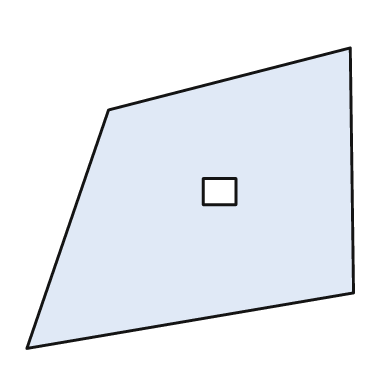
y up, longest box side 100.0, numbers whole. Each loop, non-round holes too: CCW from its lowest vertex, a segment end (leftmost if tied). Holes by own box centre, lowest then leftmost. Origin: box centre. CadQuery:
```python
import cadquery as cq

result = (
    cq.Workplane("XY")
    .moveTo(-50.0, -46.0)
    .lineTo(50.0, -29.0)
    .lineTo(49.0, 46.0)
    .lineTo(-25.0, 27.0)
    .close()
    .moveTo(4.0, -2.0)
    .lineTo(14.0, -2.0)
    .lineTo(14.0, 6.0)
    .lineTo(4.0, 6.0)
    .close()
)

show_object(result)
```